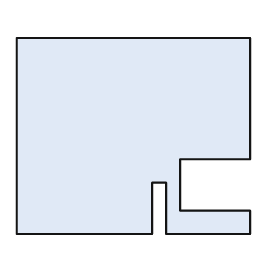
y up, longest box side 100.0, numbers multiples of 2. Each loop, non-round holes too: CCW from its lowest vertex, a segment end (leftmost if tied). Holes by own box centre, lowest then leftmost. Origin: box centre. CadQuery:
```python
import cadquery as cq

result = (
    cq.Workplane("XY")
    .moveTo(-50.0, -42.0)
    .lineTo(8.0, -42.0)
    .lineTo(8.0, -20.0)
    .lineTo(14.0, -20.0)
    .lineTo(14.0, -42.0)
    .lineTo(50.0, -42.0)
    .lineTo(50.0, -32.0)
    .lineTo(20.0, -32.0)
    .lineTo(20.0, -10.0)
    .lineTo(50.0, -10.0)
    .lineTo(50.0, 42.0)
    .lineTo(-50.0, 42.0)
    .close()
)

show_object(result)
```